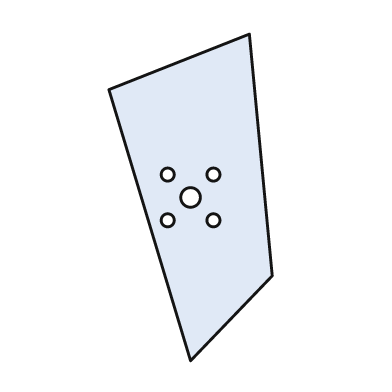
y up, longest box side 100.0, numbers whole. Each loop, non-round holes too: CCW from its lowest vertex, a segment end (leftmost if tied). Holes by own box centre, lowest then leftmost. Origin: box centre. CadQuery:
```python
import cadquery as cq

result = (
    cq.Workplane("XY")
    .moveTo(0.0, -50.0)
    .lineTo(25.0, -24.0)
    .lineTo(18.0, 50.0)
    .lineTo(-25.0, 33.0)
    .close()
    .moveTo(-7.0, -7.0)
    .circle(2.0)
    .moveTo(7.0, -7.0)
    .circle(2.0)
    .moveTo(0.0, 0.0)
    .circle(3.0)
    .moveTo(-7.0, 7.0)
    .circle(2.0)
    .moveTo(7.0, 7.0)
    .circle(2.0)
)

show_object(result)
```